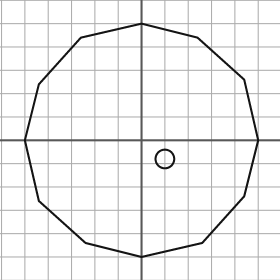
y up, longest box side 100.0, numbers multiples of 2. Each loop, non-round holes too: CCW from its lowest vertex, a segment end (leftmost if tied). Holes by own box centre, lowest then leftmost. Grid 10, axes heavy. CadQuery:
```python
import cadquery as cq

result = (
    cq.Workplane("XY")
    .moveTo(0.0, -50.0)
    .lineTo(26.0, -44.0)
    .lineTo(44.0, -24.0)
    .lineTo(50.0, 0.0)
    .lineTo(44.0, 26.0)
    .lineTo(24.0, 44.0)
    .lineTo(0.0, 50.0)
    .lineTo(-26.0, 44.0)
    .lineTo(-44.0, 24.0)
    .lineTo(-50.0, 0.0)
    .lineTo(-44.0, -26.0)
    .lineTo(-24.0, -44.0)
    .close()
    .moveTo(10.0, -8.0)
    .circle(4.0)
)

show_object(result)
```